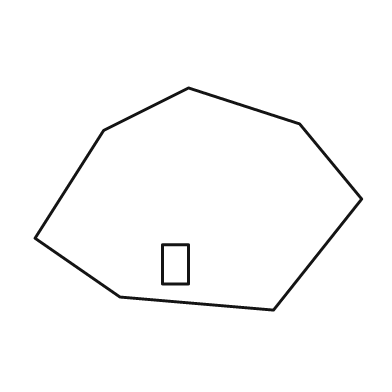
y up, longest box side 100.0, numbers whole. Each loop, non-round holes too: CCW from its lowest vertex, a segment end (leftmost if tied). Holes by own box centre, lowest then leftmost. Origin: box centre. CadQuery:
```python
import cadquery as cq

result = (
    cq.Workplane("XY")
    .moveTo(23.0, -34.0)
    .lineTo(50.0, 0.0)
    .lineTo(31.0, 23.0)
    .lineTo(-3.0, 34.0)
    .lineTo(-29.0, 21.0)
    .lineTo(-50.0, -12.0)
    .lineTo(-24.0, -30.0)
    .close()
    .moveTo(-11.0, -26.0)
    .lineTo(-3.0, -26.0)
    .lineTo(-3.0, -14.0)
    .lineTo(-11.0, -14.0)
    .close()
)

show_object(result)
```